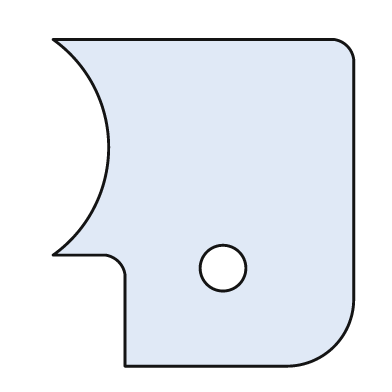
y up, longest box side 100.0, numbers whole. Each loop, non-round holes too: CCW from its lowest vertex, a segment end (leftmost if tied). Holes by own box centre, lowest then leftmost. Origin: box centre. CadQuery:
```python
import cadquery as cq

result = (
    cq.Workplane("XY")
    .moveTo(-24.0, -50.0)
    .lineTo(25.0, -50.0)
    .threePointArc((40.0, -44.0), (46.0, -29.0))
    .lineTo(46.0, 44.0)
    .threePointArc((44.0, 48.0), (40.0, 50.0))
    .lineTo(-46.0, 50.0)
    .threePointArc((-29.0, 17.0), (-46.0, -16.0))
    .lineTo(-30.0, -16.0)
    .threePointArc((-26.0, -18.0), (-24.0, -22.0))
    .close()
    .moveTo(6.0, -20.0)
    .circle(7.0)
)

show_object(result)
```